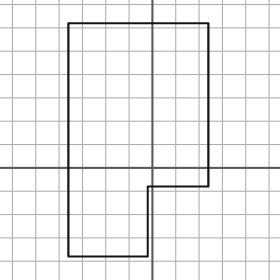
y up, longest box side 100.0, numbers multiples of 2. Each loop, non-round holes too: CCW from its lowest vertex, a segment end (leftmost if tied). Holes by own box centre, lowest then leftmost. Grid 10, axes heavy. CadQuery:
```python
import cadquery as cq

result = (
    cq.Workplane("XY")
    .moveTo(-36.0, -38.0)
    .lineTo(-2.0, -38.0)
    .lineTo(-2.0, -8.0)
    .lineTo(24.0, -8.0)
    .lineTo(24.0, 62.0)
    .lineTo(-36.0, 62.0)
    .close()
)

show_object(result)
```